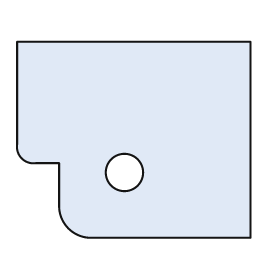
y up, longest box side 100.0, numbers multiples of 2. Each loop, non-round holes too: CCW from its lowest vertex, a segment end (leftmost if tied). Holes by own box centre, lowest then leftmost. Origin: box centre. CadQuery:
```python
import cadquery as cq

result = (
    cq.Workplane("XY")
    .moveTo(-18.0, -42.0)
    .lineTo(50.0, -42.0)
    .lineTo(50.0, 42.0)
    .lineTo(-50.0, 42.0)
    .lineTo(-50.0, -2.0)
    .threePointArc((-48.0, -8.0), (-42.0, -10.0))
    .lineTo(-32.0, -10.0)
    .lineTo(-32.0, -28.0)
    .threePointArc((-28.0, -38.0), (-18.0, -42.0))
    .close()
    .moveTo(-4.0, -14.0)
    .circle(8.0)
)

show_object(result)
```